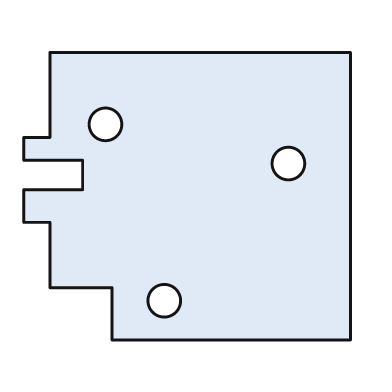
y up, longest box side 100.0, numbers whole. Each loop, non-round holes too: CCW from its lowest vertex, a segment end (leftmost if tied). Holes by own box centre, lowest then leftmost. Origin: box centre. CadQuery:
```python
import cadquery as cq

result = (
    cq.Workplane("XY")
    .moveTo(-23.0, -44.0)
    .lineTo(50.0, -44.0)
    .lineTo(50.0, 44.0)
    .lineTo(-42.0, 44.0)
    .lineTo(-42.0, 18.0)
    .lineTo(-50.0, 18.0)
    .lineTo(-50.0, 11.0)
    .lineTo(-32.0, 11.0)
    .lineTo(-32.0, 2.0)
    .lineTo(-50.0, 2.0)
    .lineTo(-50.0, -8.0)
    .lineTo(-42.0, -8.0)
    .lineTo(-42.0, -28.0)
    .lineTo(-23.0, -28.0)
    .close()
    .moveTo(-7.0, -32.0)
    .circle(5.0)
    .moveTo(31.0, 10.0)
    .circle(5.0)
    .moveTo(-25.0, 22.0)
    .circle(5.0)
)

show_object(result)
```